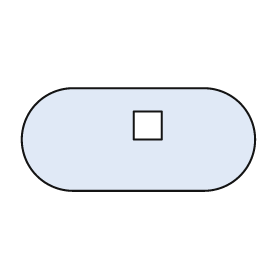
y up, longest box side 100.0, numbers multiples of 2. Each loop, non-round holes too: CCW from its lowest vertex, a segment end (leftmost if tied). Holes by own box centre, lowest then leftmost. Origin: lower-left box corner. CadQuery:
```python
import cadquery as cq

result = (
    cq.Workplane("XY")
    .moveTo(22.0, 0.0)
    .lineTo(78.0, 0.0)
    .threePointArc((100.0, 22.0), (78.0, 44.0))
    .lineTo(22.0, 44.0)
    .threePointArc((0.0, 22.0), (22.0, 0.0))
    .close()
    .moveTo(48.0, 22.0)
    .lineTo(60.0, 22.0)
    .lineTo(60.0, 34.0)
    .lineTo(48.0, 34.0)
    .close()
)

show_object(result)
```